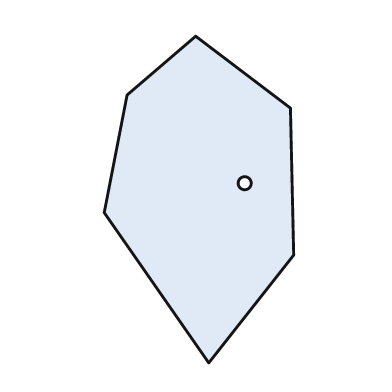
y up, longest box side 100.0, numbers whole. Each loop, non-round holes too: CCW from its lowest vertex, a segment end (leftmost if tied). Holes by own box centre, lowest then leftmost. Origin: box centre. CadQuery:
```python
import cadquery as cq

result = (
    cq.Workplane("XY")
    .moveTo(3.0, -50.0)
    .lineTo(29.0, -17.0)
    .lineTo(28.0, 28.0)
    .lineTo(-1.0, 50.0)
    .lineTo(-22.0, 32.0)
    .lineTo(-29.0, -4.0)
    .close()
    .moveTo(14.0, 5.0)
    .circle(2.0)
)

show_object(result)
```